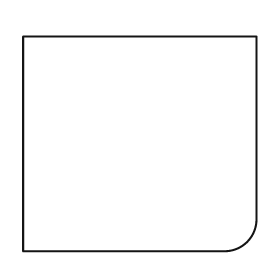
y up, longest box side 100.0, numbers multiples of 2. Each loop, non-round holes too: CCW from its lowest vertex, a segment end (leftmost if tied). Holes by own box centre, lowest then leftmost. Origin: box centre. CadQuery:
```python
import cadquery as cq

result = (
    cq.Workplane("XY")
    .moveTo(-50.0, -46.0)
    .lineTo(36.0, -46.0)
    .threePointArc((46.0, -42.0), (50.0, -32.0))
    .lineTo(50.0, 46.0)
    .lineTo(-50.0, 46.0)
    .close()
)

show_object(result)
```